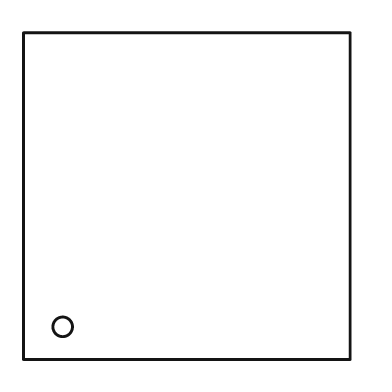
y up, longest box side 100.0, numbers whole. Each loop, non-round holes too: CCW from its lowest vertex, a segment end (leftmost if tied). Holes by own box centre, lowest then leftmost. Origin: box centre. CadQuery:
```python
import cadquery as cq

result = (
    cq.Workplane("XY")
    .moveTo(-50.0, -50.0)
    .lineTo(50.0, -50.0)
    .lineTo(50.0, 50.0)
    .lineTo(-50.0, 50.0)
    .close()
    .moveTo(-38.0, -40.0)
    .circle(3.0)
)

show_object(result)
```